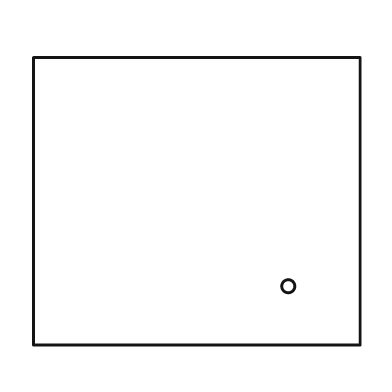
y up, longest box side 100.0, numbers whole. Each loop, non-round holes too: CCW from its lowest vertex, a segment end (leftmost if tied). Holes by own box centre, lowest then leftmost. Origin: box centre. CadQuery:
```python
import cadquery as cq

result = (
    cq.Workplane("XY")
    .moveTo(-50.0, -44.0)
    .lineTo(50.0, -44.0)
    .lineTo(50.0, 44.0)
    .lineTo(-50.0, 44.0)
    .close()
    .moveTo(28.0, -26.0)
    .circle(2.0)
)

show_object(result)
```